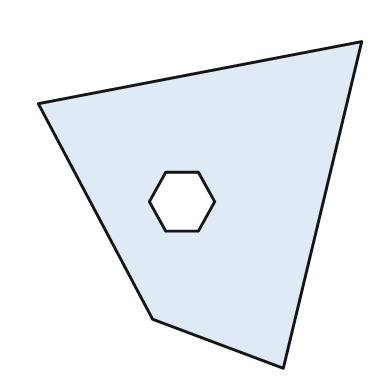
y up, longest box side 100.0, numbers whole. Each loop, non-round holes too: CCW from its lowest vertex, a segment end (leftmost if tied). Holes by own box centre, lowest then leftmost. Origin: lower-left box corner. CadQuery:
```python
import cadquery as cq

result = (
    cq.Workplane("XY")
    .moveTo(75.0, 0.0)
    .lineTo(99.0, 100.0)
    .lineTo(0.0, 81.0)
    .lineTo(35.0, 15.0)
    .close()
    .moveTo(39.0, 42.0)
    .lineTo(49.0, 42.0)
    .lineTo(54.0, 51.0)
    .lineTo(49.0, 60.0)
    .lineTo(39.0, 60.0)
    .lineTo(34.0, 51.0)
    .close()
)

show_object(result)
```